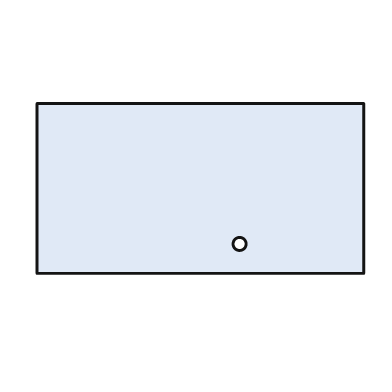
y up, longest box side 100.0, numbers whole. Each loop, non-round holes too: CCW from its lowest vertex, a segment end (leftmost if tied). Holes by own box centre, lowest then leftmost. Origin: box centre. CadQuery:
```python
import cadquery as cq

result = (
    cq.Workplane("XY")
    .moveTo(-50.0, -26.0)
    .lineTo(50.0, -26.0)
    .lineTo(50.0, 26.0)
    .lineTo(-50.0, 26.0)
    .close()
    .moveTo(12.0, -17.0)
    .circle(2.0)
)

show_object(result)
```